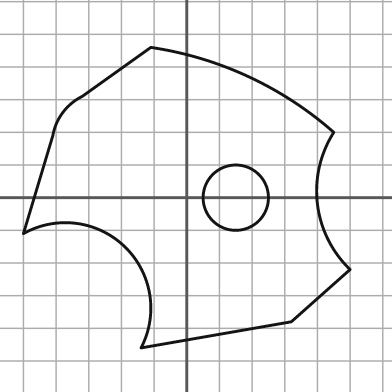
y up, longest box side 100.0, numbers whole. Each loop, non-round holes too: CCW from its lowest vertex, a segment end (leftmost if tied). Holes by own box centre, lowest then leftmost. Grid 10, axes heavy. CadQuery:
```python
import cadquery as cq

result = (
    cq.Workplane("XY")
    .moveTo(-14.0, -46.0)
    .lineTo(32.0, -38.0)
    .lineTo(50.0, -22.0)
    .threePointArc((40.0, -2.0), (45.0, 20.0))
    .threePointArc((19.0, 37.0), (-11.0, 46.0))
    .lineTo(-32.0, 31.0)
    .threePointArc((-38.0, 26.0), (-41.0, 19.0))
    .lineTo(-50.0, -11.0)
    .threePointArc((-19.0, -15.0), (-14.0, -46.0))
    .close()
    .moveTo(15.0, 0.0)
    .circle(10.0)
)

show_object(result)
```